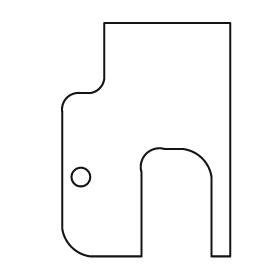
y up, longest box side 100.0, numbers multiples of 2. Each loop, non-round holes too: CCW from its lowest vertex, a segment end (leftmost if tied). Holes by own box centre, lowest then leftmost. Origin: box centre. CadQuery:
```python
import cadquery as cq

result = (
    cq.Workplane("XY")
    .moveTo(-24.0, -50.0)
    .lineTo(-2.0, -50.0)
    .lineTo(-2.0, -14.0)
    .threePointArc((0.0, -6.0), (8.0, -4.0))
    .lineTo(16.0, -4.0)
    .threePointArc((24.0, -8.0), (28.0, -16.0))
    .lineTo(28.0, -50.0)
    .lineTo(36.0, -50.0)
    .lineTo(36.0, 50.0)
    .lineTo(-18.0, 50.0)
    .lineTo(-18.0, 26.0)
    .threePointArc((-20.0, 22.0), (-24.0, 20.0))
    .lineTo(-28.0, 20.0)
    .threePointArc((-34.0, 18.0), (-36.0, 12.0))
    .lineTo(-36.0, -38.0)
    .threePointArc((-32.0, -46.0), (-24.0, -50.0))
    .close()
    .moveTo(-28.0, -16.0)
    .circle(4.0)
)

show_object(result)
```